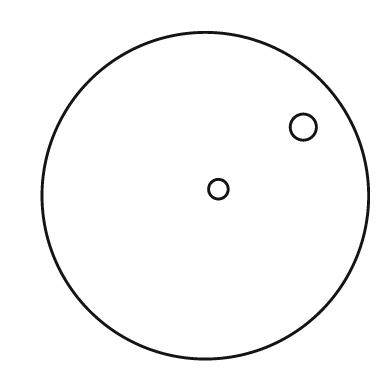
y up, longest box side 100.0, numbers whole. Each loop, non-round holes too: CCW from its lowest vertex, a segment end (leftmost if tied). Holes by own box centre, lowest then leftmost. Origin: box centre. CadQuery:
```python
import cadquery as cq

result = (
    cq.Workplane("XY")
    .moveTo(0.0, 0.0)
    .circle(50.0)
    .moveTo(4.0, 2.0)
    .circle(3.0)
    .moveTo(30.0, 21.0)
    .circle(4.0)
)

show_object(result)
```